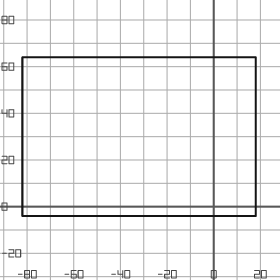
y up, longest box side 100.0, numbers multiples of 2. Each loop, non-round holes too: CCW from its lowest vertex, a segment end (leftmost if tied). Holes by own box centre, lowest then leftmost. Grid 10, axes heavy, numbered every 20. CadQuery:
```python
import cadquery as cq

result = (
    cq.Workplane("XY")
    .moveTo(-82.0, -4.0)
    .lineTo(18.0, -4.0)
    .lineTo(18.0, 64.0)
    .lineTo(-82.0, 64.0)
    .close()
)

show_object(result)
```